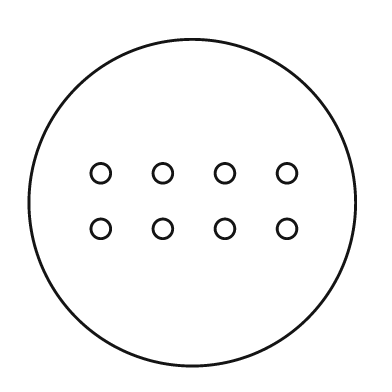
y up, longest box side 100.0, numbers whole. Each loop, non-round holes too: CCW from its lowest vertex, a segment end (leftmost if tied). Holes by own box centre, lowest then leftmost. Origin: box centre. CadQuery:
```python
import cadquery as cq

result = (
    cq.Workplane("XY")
    .moveTo(0.0, 0.0)
    .circle(50.0)
    .moveTo(-28.0, -8.0)
    .circle(3.0)
    .moveTo(-9.0, -8.0)
    .circle(3.0)
    .moveTo(10.0, -8.0)
    .circle(3.0)
    .moveTo(29.0, -8.0)
    .circle(3.0)
    .moveTo(-28.0, 9.0)
    .circle(3.0)
    .moveTo(-9.0, 9.0)
    .circle(3.0)
    .moveTo(10.0, 9.0)
    .circle(3.0)
    .moveTo(29.0, 9.0)
    .circle(3.0)
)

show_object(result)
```